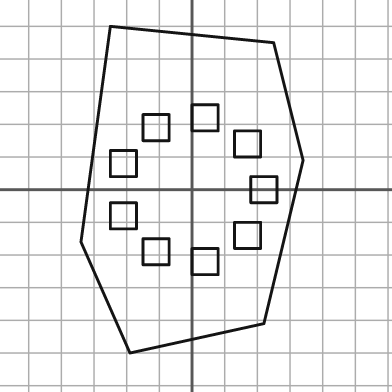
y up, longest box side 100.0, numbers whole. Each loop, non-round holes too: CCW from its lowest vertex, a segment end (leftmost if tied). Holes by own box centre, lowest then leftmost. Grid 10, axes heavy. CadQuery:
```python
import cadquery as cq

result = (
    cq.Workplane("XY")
    .moveTo(-19.0, -50.0)
    .lineTo(22.0, -41.0)
    .lineTo(34.0, 9.0)
    .lineTo(25.0, 45.0)
    .lineTo(-25.0, 50.0)
    .lineTo(-34.0, -16.0)
    .close()
    .moveTo(0.0, -26.0)
    .lineTo(8.0, -26.0)
    .lineTo(8.0, -18.0)
    .lineTo(0.0, -18.0)
    .close()
    .moveTo(-15.0, -23.0)
    .lineTo(-7.0, -23.0)
    .lineTo(-7.0, -15.0)
    .lineTo(-15.0, -15.0)
    .close()
    .moveTo(13.0, -18.0)
    .lineTo(21.0, -18.0)
    .lineTo(21.0, -10.0)
    .lineTo(13.0, -10.0)
    .close()
    .moveTo(-25.0, -12.0)
    .lineTo(-17.0, -12.0)
    .lineTo(-17.0, -4.0)
    .lineTo(-25.0, -4.0)
    .close()
    .moveTo(18.0, -4.0)
    .lineTo(26.0, -4.0)
    .lineTo(26.0, 4.0)
    .lineTo(18.0, 4.0)
    .close()
    .moveTo(-25.0, 4.0)
    .lineTo(-17.0, 4.0)
    .lineTo(-17.0, 12.0)
    .lineTo(-25.0, 12.0)
    .close()
    .moveTo(13.0, 10.0)
    .lineTo(21.0, 10.0)
    .lineTo(21.0, 18.0)
    .lineTo(13.0, 18.0)
    .close()
    .moveTo(-15.0, 15.0)
    .lineTo(-7.0, 15.0)
    .lineTo(-7.0, 23.0)
    .lineTo(-15.0, 23.0)
    .close()
    .moveTo(0.0, 18.0)
    .lineTo(8.0, 18.0)
    .lineTo(8.0, 26.0)
    .lineTo(0.0, 26.0)
    .close()
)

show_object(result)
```